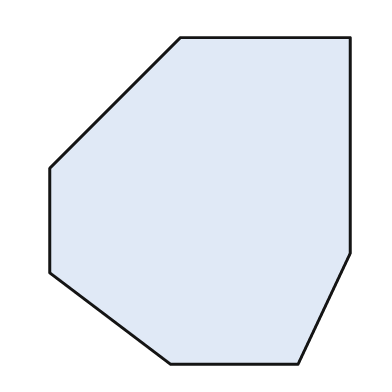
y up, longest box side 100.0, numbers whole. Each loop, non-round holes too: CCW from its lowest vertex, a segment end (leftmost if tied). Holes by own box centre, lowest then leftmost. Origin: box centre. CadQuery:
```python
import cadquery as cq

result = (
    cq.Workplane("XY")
    .moveTo(-9.0, -50.0)
    .lineTo(30.0, -50.0)
    .lineTo(46.0, -16.0)
    .lineTo(46.0, 50.0)
    .lineTo(-6.0, 50.0)
    .lineTo(-46.0, 10.0)
    .lineTo(-46.0, -22.0)
    .close()
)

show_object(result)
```